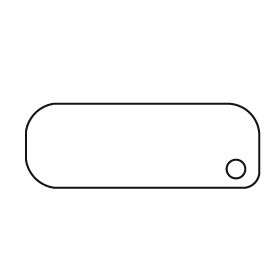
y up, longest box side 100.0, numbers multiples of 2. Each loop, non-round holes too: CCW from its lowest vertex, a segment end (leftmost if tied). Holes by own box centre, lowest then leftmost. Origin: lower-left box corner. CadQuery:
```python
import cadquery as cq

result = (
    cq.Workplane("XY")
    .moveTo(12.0, 0.0)
    .lineTo(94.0, 0.0)
    .threePointArc((98.0, 2.0), (100.0, 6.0))
    .lineTo(100.0, 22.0)
    .threePointArc((96.0, 32.0), (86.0, 36.0))
    .lineTo(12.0, 36.0)
    .threePointArc((4.0, 32.0), (0.0, 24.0))
    .lineTo(0.0, 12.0)
    .threePointArc((4.0, 4.0), (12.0, 0.0))
    .close()
    .moveTo(90.0, 8.0)
    .circle(4.0)
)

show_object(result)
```